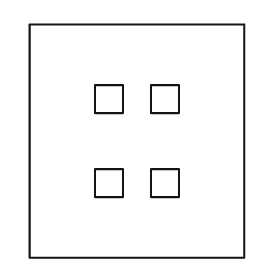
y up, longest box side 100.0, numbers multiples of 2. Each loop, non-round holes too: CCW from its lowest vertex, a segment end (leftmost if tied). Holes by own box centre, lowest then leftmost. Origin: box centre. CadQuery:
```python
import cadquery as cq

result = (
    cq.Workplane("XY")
    .moveTo(-46.0, -50.0)
    .lineTo(46.0, -50.0)
    .lineTo(46.0, 50.0)
    .lineTo(-46.0, 50.0)
    .close()
    .moveTo(-18.0, -24.0)
    .lineTo(-6.0, -24.0)
    .lineTo(-6.0, -12.0)
    .lineTo(-18.0, -12.0)
    .close()
    .moveTo(6.0, -24.0)
    .lineTo(18.0, -24.0)
    .lineTo(18.0, -12.0)
    .lineTo(6.0, -12.0)
    .close()
    .moveTo(-18.0, 12.0)
    .lineTo(-6.0, 12.0)
    .lineTo(-6.0, 24.0)
    .lineTo(-18.0, 24.0)
    .close()
    .moveTo(6.0, 12.0)
    .lineTo(18.0, 12.0)
    .lineTo(18.0, 24.0)
    .lineTo(6.0, 24.0)
    .close()
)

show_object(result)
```